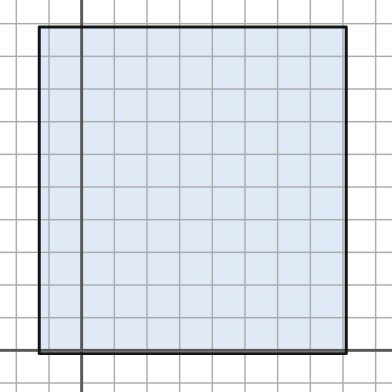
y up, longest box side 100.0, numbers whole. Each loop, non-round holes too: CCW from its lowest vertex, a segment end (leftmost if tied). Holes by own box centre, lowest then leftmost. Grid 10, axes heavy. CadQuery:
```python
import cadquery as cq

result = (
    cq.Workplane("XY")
    .moveTo(-13.0, -1.0)
    .lineTo(81.0, -1.0)
    .lineTo(81.0, 99.0)
    .lineTo(-13.0, 99.0)
    .close()
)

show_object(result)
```